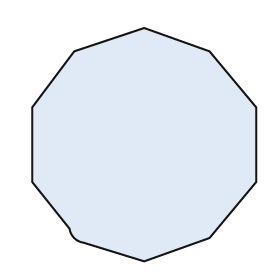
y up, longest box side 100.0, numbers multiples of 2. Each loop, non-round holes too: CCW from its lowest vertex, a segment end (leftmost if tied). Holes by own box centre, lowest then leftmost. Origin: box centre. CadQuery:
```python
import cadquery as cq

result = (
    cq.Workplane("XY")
    .moveTo(0.0, -50.0)
    .lineTo(28.0, -40.0)
    .lineTo(48.0, -16.0)
    .lineTo(48.0, 16.0)
    .lineTo(28.0, 40.0)
    .lineTo(0.0, 50.0)
    .lineTo(-30.0, 40.0)
    .lineTo(-48.0, 16.0)
    .lineTo(-48.0, -16.0)
    .lineTo(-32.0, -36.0)
    .threePointArc((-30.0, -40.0), (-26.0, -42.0))
    .close()
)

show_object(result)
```